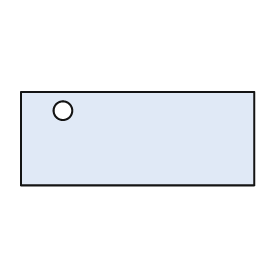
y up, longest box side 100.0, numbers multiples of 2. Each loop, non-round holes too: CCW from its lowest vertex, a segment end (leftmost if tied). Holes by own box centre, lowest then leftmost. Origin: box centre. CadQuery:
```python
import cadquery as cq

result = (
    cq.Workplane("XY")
    .moveTo(-50.0, -20.0)
    .lineTo(50.0, -20.0)
    .lineTo(50.0, 20.0)
    .lineTo(-50.0, 20.0)
    .close()
    .moveTo(-32.0, 12.0)
    .circle(4.0)
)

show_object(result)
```